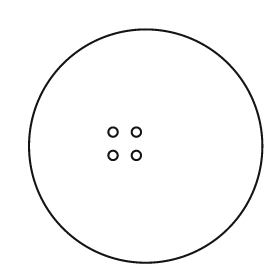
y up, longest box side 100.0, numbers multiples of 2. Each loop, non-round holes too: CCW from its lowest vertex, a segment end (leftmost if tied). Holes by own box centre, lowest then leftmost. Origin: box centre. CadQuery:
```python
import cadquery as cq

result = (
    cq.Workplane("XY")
    .moveTo(0.0, 0.0)
    .circle(50.0)
    .moveTo(-14.0, -4.0)
    .circle(2.0)
    .moveTo(-4.0, -4.0)
    .circle(2.0)
    .moveTo(-14.0, 6.0)
    .circle(2.0)
    .moveTo(-4.0, 6.0)
    .circle(2.0)
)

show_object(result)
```